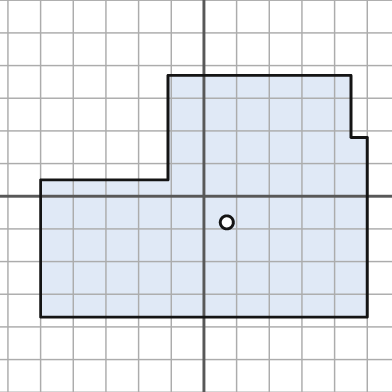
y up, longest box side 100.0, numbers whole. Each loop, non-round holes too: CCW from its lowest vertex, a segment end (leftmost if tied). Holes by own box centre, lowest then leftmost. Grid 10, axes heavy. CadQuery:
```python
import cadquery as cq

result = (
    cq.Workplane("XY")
    .moveTo(-50.0, -37.0)
    .lineTo(50.0, -37.0)
    .lineTo(50.0, 18.0)
    .lineTo(45.0, 18.0)
    .lineTo(45.0, 37.0)
    .lineTo(-11.0, 37.0)
    .lineTo(-11.0, 5.0)
    .lineTo(-50.0, 5.0)
    .close()
    .moveTo(7.0, -8.0)
    .circle(2.0)
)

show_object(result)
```